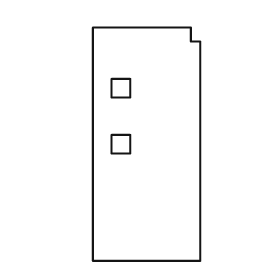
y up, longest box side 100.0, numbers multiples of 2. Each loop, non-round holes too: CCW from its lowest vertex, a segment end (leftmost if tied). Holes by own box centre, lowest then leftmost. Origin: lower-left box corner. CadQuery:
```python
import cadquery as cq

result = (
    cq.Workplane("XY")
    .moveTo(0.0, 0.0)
    .lineTo(46.0, 0.0)
    .lineTo(46.0, 94.0)
    .lineTo(42.0, 94.0)
    .lineTo(42.0, 100.0)
    .lineTo(0.0, 100.0)
    .close()
    .moveTo(8.0, 46.0)
    .lineTo(16.0, 46.0)
    .lineTo(16.0, 54.0)
    .lineTo(8.0, 54.0)
    .close()
    .moveTo(8.0, 70.0)
    .lineTo(16.0, 70.0)
    .lineTo(16.0, 78.0)
    .lineTo(8.0, 78.0)
    .close()
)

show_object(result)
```